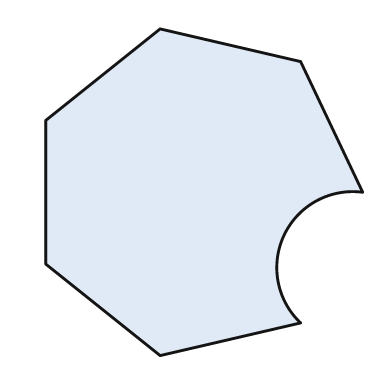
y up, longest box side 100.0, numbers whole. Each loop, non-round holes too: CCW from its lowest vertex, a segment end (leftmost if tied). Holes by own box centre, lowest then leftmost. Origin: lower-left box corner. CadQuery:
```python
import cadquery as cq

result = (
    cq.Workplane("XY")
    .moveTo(35.0, 0.0)
    .lineTo(78.0, 10.0)
    .threePointArc((73.0, 37.0), (97.0, 50.0))
    .lineTo(78.0, 90.0)
    .lineTo(35.0, 100.0)
    .lineTo(0.0, 72.0)
    .lineTo(0.0, 28.0)
    .close()
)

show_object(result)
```